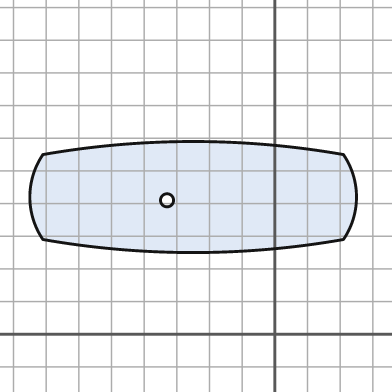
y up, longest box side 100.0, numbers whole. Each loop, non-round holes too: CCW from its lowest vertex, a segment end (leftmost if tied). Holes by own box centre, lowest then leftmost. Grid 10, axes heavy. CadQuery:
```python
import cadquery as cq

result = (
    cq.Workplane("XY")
    .moveTo(-71.0, 29.0)
    .threePointArc((-25.0, 25.0), (21.0, 29.0))
    .threePointArc((25.0, 42.0), (21.0, 55.0))
    .threePointArc((-25.0, 59.0), (-71.0, 55.0))
    .threePointArc((-75.0, 42.0), (-71.0, 29.0))
    .close()
    .moveTo(-33.0, 41.0)
    .circle(2.0)
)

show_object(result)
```